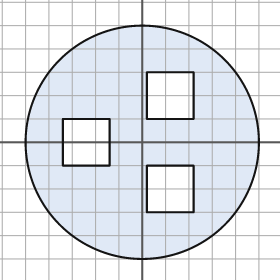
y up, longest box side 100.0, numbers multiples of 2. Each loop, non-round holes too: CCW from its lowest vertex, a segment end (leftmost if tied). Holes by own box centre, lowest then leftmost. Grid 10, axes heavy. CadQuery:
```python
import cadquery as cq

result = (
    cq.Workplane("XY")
    .moveTo(0.0, 0.0)
    .circle(50.0)
    .moveTo(2.0, -30.0)
    .lineTo(22.0, -30.0)
    .lineTo(22.0, -10.0)
    .lineTo(2.0, -10.0)
    .close()
    .moveTo(-34.0, -10.0)
    .lineTo(-14.0, -10.0)
    .lineTo(-14.0, 10.0)
    .lineTo(-34.0, 10.0)
    .close()
    .moveTo(2.0, 10.0)
    .lineTo(22.0, 10.0)
    .lineTo(22.0, 30.0)
    .lineTo(2.0, 30.0)
    .close()
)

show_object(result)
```